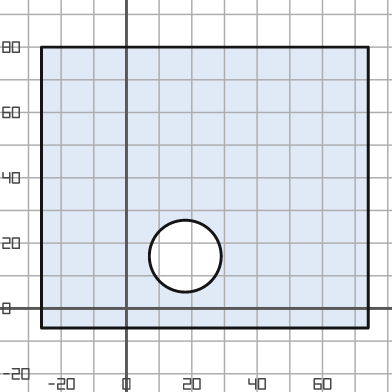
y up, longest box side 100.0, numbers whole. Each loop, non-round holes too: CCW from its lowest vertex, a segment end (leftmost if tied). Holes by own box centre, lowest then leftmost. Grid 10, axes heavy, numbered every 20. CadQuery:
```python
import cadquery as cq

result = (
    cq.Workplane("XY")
    .moveTo(-26.0, -6.0)
    .lineTo(74.0, -6.0)
    .lineTo(74.0, 80.0)
    .lineTo(-26.0, 80.0)
    .close()
    .moveTo(18.0, 16.0)
    .circle(11.0)
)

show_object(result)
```